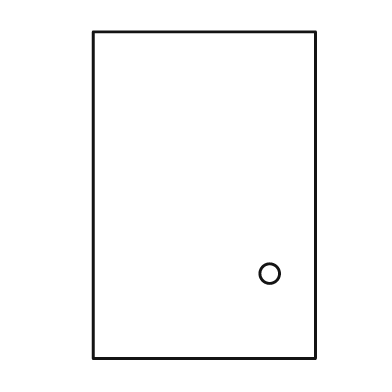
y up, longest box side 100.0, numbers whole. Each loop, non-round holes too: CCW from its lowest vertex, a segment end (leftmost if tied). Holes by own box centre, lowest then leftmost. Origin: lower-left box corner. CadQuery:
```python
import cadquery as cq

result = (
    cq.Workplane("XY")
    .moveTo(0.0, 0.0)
    .lineTo(68.0, 0.0)
    .lineTo(68.0, 100.0)
    .lineTo(0.0, 100.0)
    .close()
    .moveTo(54.0, 26.0)
    .circle(3.0)
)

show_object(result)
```